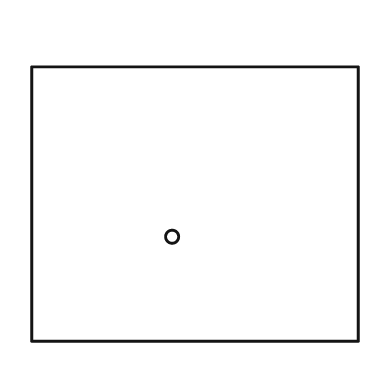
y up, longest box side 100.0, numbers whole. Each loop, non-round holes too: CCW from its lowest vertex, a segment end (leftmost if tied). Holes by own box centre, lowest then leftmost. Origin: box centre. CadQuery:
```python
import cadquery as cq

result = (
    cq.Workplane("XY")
    .moveTo(-50.0, -42.0)
    .lineTo(50.0, -42.0)
    .lineTo(50.0, 42.0)
    .lineTo(-50.0, 42.0)
    .close()
    .moveTo(-7.0, -10.0)
    .circle(2.0)
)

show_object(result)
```